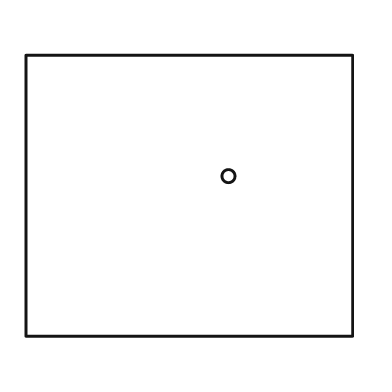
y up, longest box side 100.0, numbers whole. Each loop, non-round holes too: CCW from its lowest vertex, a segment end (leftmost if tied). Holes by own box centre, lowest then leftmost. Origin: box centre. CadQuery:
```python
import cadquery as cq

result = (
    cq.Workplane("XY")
    .moveTo(-50.0, -43.0)
    .lineTo(50.0, -43.0)
    .lineTo(50.0, 43.0)
    .lineTo(-50.0, 43.0)
    .close()
    .moveTo(12.0, 6.0)
    .circle(2.0)
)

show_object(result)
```